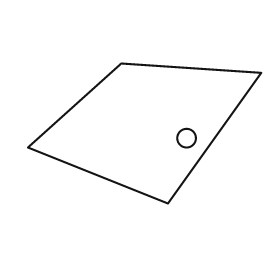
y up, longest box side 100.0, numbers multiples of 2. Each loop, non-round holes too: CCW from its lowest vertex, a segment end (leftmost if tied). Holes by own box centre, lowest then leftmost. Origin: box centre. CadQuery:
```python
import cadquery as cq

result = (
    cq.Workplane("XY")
    .moveTo(10.0, -30.0)
    .lineTo(50.0, 26.0)
    .lineTo(-10.0, 30.0)
    .lineTo(-50.0, -6.0)
    .close()
    .moveTo(18.0, -2.0)
    .circle(4.0)
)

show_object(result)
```